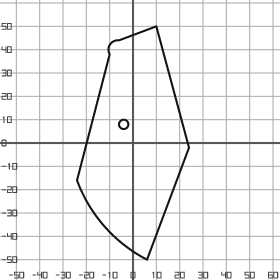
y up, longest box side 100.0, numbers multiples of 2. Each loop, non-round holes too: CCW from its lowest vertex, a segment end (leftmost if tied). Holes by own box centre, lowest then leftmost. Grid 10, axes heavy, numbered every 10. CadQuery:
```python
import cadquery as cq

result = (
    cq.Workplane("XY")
    .moveTo(6.0, -50.0)
    .lineTo(24.0, -2.0)
    .lineTo(10.0, 50.0)
    .lineTo(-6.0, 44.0)
    .threePointArc((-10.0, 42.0), (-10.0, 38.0))
    .lineTo(-24.0, -16.0)
    .threePointArc((-12.0, -36.0), (6.0, -50.0))
    .close()
    .moveTo(-4.0, 8.0)
    .circle(2.0)
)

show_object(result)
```